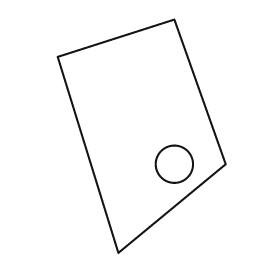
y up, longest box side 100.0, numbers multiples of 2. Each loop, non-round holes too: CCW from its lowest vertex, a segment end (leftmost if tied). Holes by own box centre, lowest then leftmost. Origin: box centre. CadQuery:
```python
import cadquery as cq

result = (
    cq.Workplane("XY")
    .moveTo(-10.0, -50.0)
    .lineTo(36.0, -12.0)
    .lineTo(14.0, 50.0)
    .lineTo(-36.0, 34.0)
    .close()
    .moveTo(14.0, -12.0)
    .circle(8.0)
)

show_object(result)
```